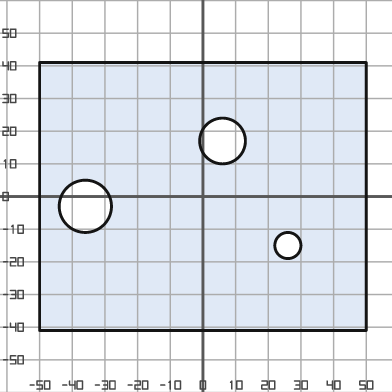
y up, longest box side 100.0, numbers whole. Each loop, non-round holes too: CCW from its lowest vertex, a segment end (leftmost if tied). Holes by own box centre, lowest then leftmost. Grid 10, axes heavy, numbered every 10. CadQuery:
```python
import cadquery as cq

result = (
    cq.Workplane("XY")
    .moveTo(-50.0, -41.0)
    .lineTo(50.0, -41.0)
    .lineTo(50.0, 41.0)
    .lineTo(-50.0, 41.0)
    .close()
    .moveTo(26.0, -15.0)
    .circle(4.0)
    .moveTo(-36.0, -3.0)
    .circle(8.0)
    .moveTo(6.0, 17.0)
    .circle(7.0)
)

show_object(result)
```